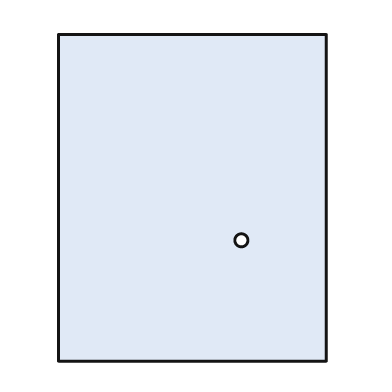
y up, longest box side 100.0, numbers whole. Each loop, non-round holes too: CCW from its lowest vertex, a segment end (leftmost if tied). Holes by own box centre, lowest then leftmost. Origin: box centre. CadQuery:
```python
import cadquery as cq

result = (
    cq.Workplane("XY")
    .moveTo(-41.0, -50.0)
    .lineTo(41.0, -50.0)
    .lineTo(41.0, 50.0)
    .lineTo(-41.0, 50.0)
    .close()
    .moveTo(15.0, -13.0)
    .circle(2.0)
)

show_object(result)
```